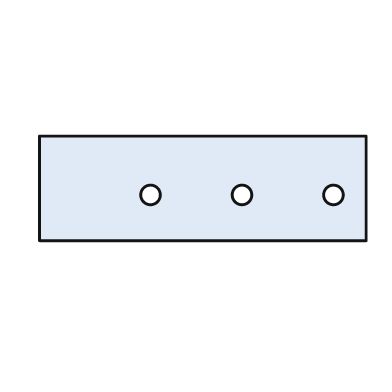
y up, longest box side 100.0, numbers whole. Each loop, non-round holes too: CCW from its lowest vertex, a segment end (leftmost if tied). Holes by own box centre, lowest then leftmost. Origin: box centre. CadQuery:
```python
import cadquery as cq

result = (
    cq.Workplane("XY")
    .moveTo(-50.0, -16.0)
    .lineTo(50.0, -16.0)
    .lineTo(50.0, 16.0)
    .lineTo(-50.0, 16.0)
    .close()
    .moveTo(-16.0, -2.0)
    .circle(3.0)
    .moveTo(12.0, -2.0)
    .circle(3.0)
    .moveTo(40.0, -2.0)
    .circle(3.0)
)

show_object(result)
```